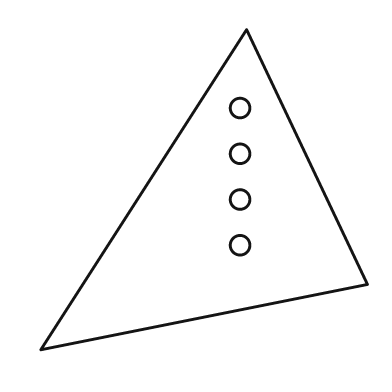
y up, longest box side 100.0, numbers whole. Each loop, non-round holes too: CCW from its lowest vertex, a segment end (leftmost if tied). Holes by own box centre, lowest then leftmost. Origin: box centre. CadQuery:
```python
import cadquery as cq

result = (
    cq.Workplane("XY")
    .moveTo(-50.0, -49.0)
    .lineTo(50.0, -29.0)
    .lineTo(13.0, 49.0)
    .close()
    .moveTo(11.0, -17.0)
    .circle(3.0)
    .moveTo(11.0, -3.0)
    .circle(3.0)
    .moveTo(11.0, 11.0)
    .circle(3.0)
    .moveTo(11.0, 25.0)
    .circle(3.0)
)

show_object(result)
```